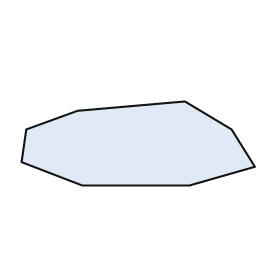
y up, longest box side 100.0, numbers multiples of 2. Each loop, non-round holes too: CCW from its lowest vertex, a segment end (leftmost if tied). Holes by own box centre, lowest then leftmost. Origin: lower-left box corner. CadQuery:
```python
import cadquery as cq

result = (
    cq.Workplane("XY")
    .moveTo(26.0, 0.0)
    .lineTo(72.0, 0.0)
    .lineTo(100.0, 8.0)
    .lineTo(90.0, 24.0)
    .lineTo(70.0, 36.0)
    .lineTo(24.0, 32.0)
    .lineTo(2.0, 24.0)
    .lineTo(0.0, 10.0)
    .close()
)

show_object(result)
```